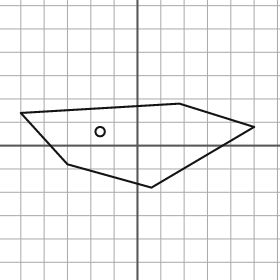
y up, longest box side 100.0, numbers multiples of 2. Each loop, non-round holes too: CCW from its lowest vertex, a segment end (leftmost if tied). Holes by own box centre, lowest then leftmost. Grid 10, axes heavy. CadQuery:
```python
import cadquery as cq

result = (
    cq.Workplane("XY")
    .moveTo(6.0, -18.0)
    .lineTo(50.0, 8.0)
    .lineTo(18.0, 18.0)
    .lineTo(-50.0, 14.0)
    .lineTo(-30.0, -8.0)
    .close()
    .moveTo(-16.0, 6.0)
    .circle(2.0)
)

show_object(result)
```